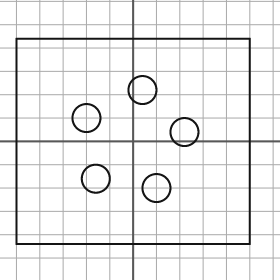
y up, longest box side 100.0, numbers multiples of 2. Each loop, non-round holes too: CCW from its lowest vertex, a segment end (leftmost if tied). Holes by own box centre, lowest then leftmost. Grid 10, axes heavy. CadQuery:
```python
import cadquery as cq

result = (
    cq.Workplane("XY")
    .moveTo(-50.0, -44.0)
    .lineTo(50.0, -44.0)
    .lineTo(50.0, 44.0)
    .lineTo(-50.0, 44.0)
    .close()
    .moveTo(10.0, -20.0)
    .circle(6.0)
    .moveTo(-16.0, -16.0)
    .circle(6.0)
    .moveTo(22.0, 4.0)
    .circle(6.0)
    .moveTo(-20.0, 10.0)
    .circle(6.0)
    .moveTo(4.0, 22.0)
    .circle(6.0)
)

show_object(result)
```